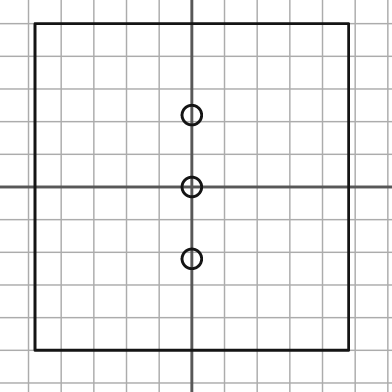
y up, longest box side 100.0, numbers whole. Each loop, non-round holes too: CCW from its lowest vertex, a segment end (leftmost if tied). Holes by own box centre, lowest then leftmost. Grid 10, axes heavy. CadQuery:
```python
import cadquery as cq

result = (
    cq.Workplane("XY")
    .moveTo(-48.0, -50.0)
    .lineTo(48.0, -50.0)
    .lineTo(48.0, 50.0)
    .lineTo(-48.0, 50.0)
    .close()
    .moveTo(0.0, -22.0)
    .circle(3.0)
    .moveTo(0.0, 0.0)
    .circle(3.0)
    .moveTo(0.0, 22.0)
    .circle(3.0)
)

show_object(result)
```